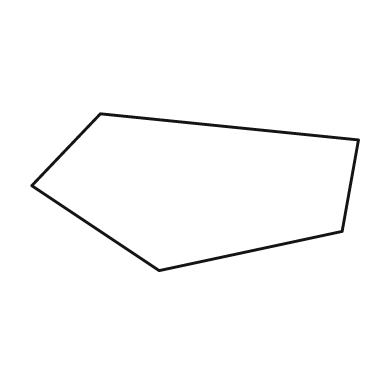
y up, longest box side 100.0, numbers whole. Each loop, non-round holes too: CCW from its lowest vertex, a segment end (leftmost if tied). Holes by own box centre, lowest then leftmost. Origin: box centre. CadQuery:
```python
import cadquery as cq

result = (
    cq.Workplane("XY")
    .moveTo(-11.0, -24.0)
    .lineTo(45.0, -12.0)
    .lineTo(50.0, 16.0)
    .lineTo(-29.0, 24.0)
    .lineTo(-50.0, 2.0)
    .close()
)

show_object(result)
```